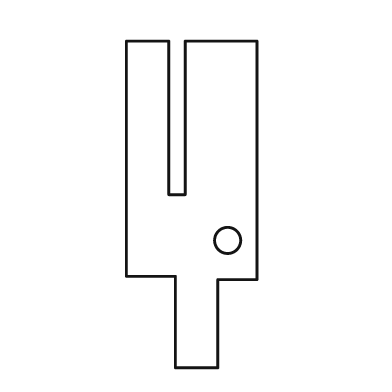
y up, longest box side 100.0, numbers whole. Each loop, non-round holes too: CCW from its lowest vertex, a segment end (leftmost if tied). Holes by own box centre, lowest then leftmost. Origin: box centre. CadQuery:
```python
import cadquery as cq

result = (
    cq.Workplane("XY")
    .moveTo(-5.0, -50.0)
    .lineTo(8.0, -50.0)
    .lineTo(8.0, -23.0)
    .lineTo(20.0, -23.0)
    .lineTo(20.0, 50.0)
    .lineTo(-2.0, 50.0)
    .lineTo(-2.0, 3.0)
    .lineTo(-7.0, 3.0)
    .lineTo(-7.0, 50.0)
    .lineTo(-20.0, 50.0)
    .lineTo(-20.0, -22.0)
    .lineTo(-5.0, -22.0)
    .close()
    .moveTo(11.0, -11.0)
    .circle(4.0)
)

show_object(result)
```